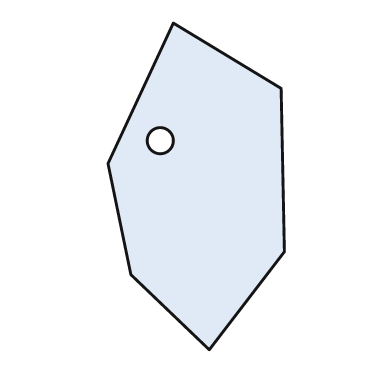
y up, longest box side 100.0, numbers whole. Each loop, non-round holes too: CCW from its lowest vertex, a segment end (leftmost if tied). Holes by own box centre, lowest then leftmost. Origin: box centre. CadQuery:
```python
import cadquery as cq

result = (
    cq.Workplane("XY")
    .moveTo(4.0, -50.0)
    .lineTo(27.0, -20.0)
    .lineTo(26.0, 30.0)
    .lineTo(-7.0, 50.0)
    .lineTo(-27.0, 7.0)
    .lineTo(-20.0, -27.0)
    .close()
    .moveTo(-11.0, 14.0)
    .circle(4.0)
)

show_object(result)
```